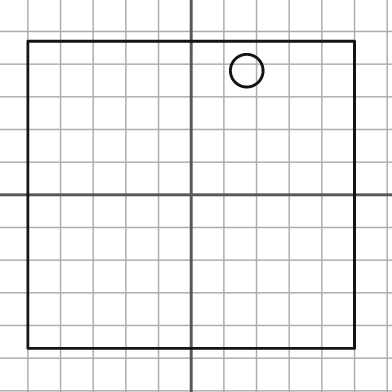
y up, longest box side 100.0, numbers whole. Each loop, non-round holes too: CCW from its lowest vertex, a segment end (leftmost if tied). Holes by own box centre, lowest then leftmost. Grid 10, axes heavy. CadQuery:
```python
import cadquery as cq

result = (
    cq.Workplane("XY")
    .moveTo(-50.0, -47.0)
    .lineTo(50.0, -47.0)
    .lineTo(50.0, 47.0)
    .lineTo(-50.0, 47.0)
    .close()
    .moveTo(17.0, 38.0)
    .circle(5.0)
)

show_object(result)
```